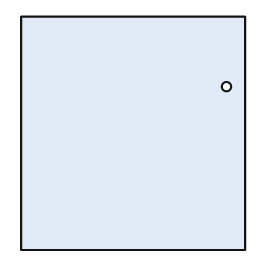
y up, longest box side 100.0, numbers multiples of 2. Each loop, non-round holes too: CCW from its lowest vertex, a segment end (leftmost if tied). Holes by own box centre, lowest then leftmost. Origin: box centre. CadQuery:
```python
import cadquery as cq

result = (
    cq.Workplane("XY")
    .moveTo(-48.0, -50.0)
    .lineTo(48.0, -50.0)
    .lineTo(48.0, 50.0)
    .lineTo(-48.0, 50.0)
    .close()
    .moveTo(40.0, 20.0)
    .circle(2.0)
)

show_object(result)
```